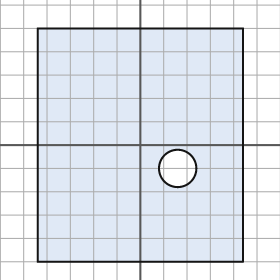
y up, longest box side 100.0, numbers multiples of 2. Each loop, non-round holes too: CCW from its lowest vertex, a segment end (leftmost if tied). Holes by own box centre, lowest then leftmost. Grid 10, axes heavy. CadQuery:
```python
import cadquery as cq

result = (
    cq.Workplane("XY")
    .moveTo(-44.0, -50.0)
    .lineTo(44.0, -50.0)
    .lineTo(44.0, 50.0)
    .lineTo(-44.0, 50.0)
    .close()
    .moveTo(16.0, -10.0)
    .circle(8.0)
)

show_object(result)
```